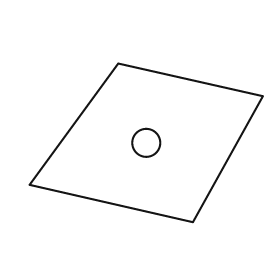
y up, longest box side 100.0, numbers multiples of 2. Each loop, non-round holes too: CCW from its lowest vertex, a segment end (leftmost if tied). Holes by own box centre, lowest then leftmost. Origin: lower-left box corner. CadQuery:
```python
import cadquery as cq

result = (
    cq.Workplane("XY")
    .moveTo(70.0, 0.0)
    .lineTo(100.0, 54.0)
    .lineTo(38.0, 68.0)
    .lineTo(0.0, 16.0)
    .close()
    .moveTo(50.0, 34.0)
    .circle(6.0)
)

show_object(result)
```